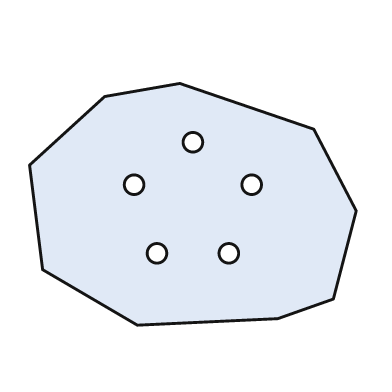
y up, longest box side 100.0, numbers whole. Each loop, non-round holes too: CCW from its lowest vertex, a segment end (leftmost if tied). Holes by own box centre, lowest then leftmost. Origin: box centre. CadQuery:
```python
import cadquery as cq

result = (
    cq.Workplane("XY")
    .moveTo(-17.0, -37.0)
    .lineTo(26.0, -35.0)
    .lineTo(43.0, -29.0)
    .lineTo(50.0, -2.0)
    .lineTo(37.0, 23.0)
    .lineTo(-4.0, 37.0)
    .lineTo(-27.0, 33.0)
    .lineTo(-50.0, 12.0)
    .lineTo(-46.0, -20.0)
    .close()
    .moveTo(-11.0, -15.0)
    .circle(3.0)
    .moveTo(11.0, -15.0)
    .circle(3.0)
    .moveTo(-18.0, 6.0)
    .circle(3.0)
    .moveTo(18.0, 6.0)
    .circle(3.0)
    .moveTo(0.0, 19.0)
    .circle(3.0)
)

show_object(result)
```